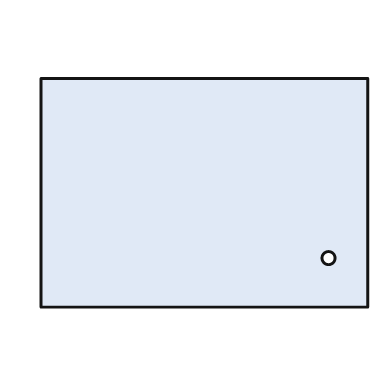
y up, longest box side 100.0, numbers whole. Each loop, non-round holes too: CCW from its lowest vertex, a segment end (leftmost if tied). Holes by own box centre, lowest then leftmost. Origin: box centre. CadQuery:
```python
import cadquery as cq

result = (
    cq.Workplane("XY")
    .moveTo(-50.0, -35.0)
    .lineTo(50.0, -35.0)
    .lineTo(50.0, 35.0)
    .lineTo(-50.0, 35.0)
    .close()
    .moveTo(38.0, -20.0)
    .circle(2.0)
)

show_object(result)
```